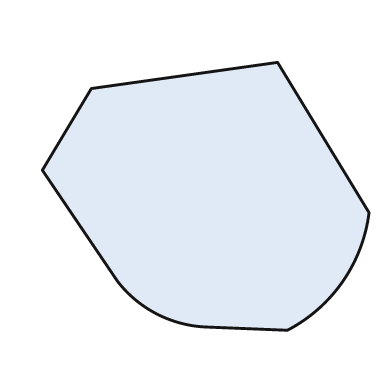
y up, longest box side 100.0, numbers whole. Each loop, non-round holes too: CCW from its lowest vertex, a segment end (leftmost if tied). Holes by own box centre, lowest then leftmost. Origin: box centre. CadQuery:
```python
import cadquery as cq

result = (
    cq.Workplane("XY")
    .moveTo(25.0, -41.0)
    .threePointArc((42.0, -26.0), (50.0, -5.0))
    .lineTo(22.0, 41.0)
    .lineTo(-35.0, 33.0)
    .lineTo(-50.0, 8.0)
    .lineTo(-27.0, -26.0)
    .threePointArc((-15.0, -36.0), (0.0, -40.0))
    .close()
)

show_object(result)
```